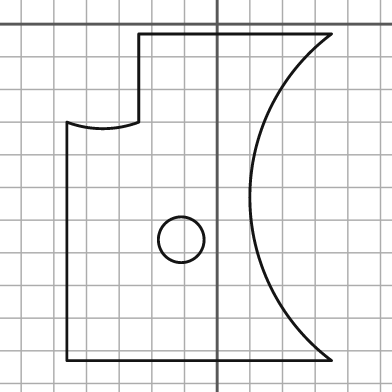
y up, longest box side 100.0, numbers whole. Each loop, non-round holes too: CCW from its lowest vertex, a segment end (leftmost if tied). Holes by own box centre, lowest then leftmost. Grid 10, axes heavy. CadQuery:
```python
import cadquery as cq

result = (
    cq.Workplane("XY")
    .moveTo(-46.0, -103.0)
    .lineTo(35.0, -103.0)
    .threePointArc((10.0, -53.0), (35.0, -3.0))
    .lineTo(-24.0, -3.0)
    .lineTo(-24.0, -30.0)
    .threePointArc((-35.0, -32.0), (-46.0, -30.0))
    .close()
    .moveTo(-11.0, -66.0)
    .circle(7.0)
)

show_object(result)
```